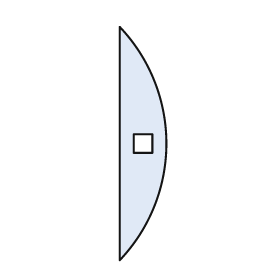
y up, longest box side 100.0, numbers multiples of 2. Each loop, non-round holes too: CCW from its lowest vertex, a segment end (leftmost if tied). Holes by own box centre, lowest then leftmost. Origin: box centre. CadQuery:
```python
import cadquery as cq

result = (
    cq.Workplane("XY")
    .moveTo(-10.0, -50.0)
    .threePointArc((10.0, 0.0), (-10.0, 50.0))
    .close()
    .moveTo(-4.0, -4.0)
    .lineTo(4.0, -4.0)
    .lineTo(4.0, 4.0)
    .lineTo(-4.0, 4.0)
    .close()
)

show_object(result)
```